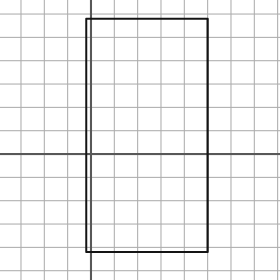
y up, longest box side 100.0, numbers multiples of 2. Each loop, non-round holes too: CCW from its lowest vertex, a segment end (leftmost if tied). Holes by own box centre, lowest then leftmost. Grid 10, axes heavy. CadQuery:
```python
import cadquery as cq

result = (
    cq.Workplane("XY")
    .moveTo(-2.0, -42.0)
    .lineTo(50.0, -42.0)
    .lineTo(50.0, 58.0)
    .lineTo(-2.0, 58.0)
    .close()
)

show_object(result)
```